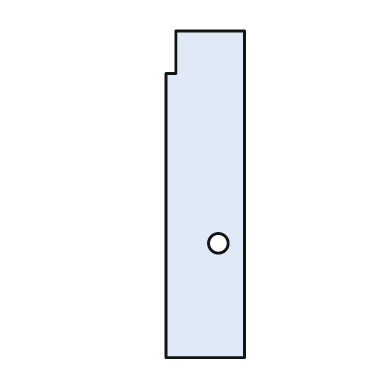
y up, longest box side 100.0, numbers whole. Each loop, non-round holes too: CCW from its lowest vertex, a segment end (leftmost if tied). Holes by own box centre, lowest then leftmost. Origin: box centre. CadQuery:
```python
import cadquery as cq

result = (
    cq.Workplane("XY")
    .moveTo(-12.0, -50.0)
    .lineTo(12.0, -50.0)
    .lineTo(12.0, 50.0)
    .lineTo(-9.0, 50.0)
    .lineTo(-9.0, 37.0)
    .lineTo(-12.0, 37.0)
    .close()
    .moveTo(4.0, -15.0)
    .circle(3.0)
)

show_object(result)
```